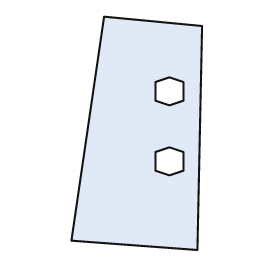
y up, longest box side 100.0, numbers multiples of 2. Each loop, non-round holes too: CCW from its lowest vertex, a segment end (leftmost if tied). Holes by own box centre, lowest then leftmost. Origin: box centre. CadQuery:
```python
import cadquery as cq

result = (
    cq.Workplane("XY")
    .moveTo(26.0, -50.0)
    .lineTo(28.0, 46.0)
    .lineTo(-14.0, 50.0)
    .lineTo(-28.0, -46.0)
    .close()
    .moveTo(14.0, -18.0)
    .lineTo(20.0, -16.0)
    .lineTo(20.0, -8.0)
    .lineTo(14.0, -6.0)
    .lineTo(8.0, -8.0)
    .lineTo(8.0, -16.0)
    .close()
    .moveTo(14.0, 12.0)
    .lineTo(20.0, 14.0)
    .lineTo(20.0, 22.0)
    .lineTo(14.0, 24.0)
    .lineTo(8.0, 22.0)
    .lineTo(8.0, 14.0)
    .close()
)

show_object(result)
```